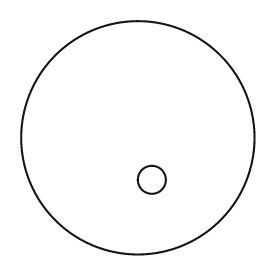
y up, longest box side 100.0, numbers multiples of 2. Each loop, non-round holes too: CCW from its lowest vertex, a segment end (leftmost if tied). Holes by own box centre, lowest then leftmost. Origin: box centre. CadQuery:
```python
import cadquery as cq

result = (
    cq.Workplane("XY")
    .moveTo(0.0, 0.0)
    .circle(50.0)
    .moveTo(6.0, -18.0)
    .circle(6.0)
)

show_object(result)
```